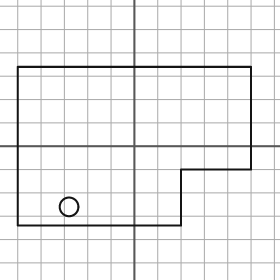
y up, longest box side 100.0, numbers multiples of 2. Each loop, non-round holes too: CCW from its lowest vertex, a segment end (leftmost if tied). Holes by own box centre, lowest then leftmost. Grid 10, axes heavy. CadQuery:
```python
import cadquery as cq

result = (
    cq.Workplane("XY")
    .moveTo(-50.0, -34.0)
    .lineTo(20.0, -34.0)
    .lineTo(20.0, -10.0)
    .lineTo(50.0, -10.0)
    .lineTo(50.0, 34.0)
    .lineTo(-50.0, 34.0)
    .close()
    .moveTo(-28.0, -26.0)
    .circle(4.0)
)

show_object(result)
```